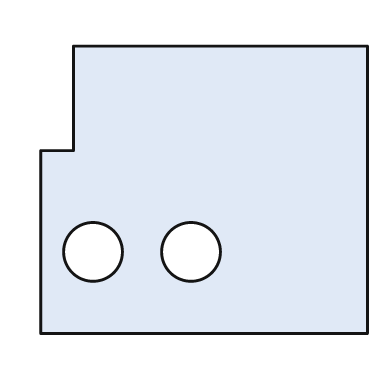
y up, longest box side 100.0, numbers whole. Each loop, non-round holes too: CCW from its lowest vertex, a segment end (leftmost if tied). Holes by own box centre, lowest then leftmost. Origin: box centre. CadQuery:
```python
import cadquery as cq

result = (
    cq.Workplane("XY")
    .moveTo(-50.0, -44.0)
    .lineTo(50.0, -44.0)
    .lineTo(50.0, 44.0)
    .lineTo(-40.0, 44.0)
    .lineTo(-40.0, 12.0)
    .lineTo(-50.0, 12.0)
    .close()
    .moveTo(-34.0, -19.0)
    .circle(9.0)
    .moveTo(-4.0, -19.0)
    .circle(9.0)
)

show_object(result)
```